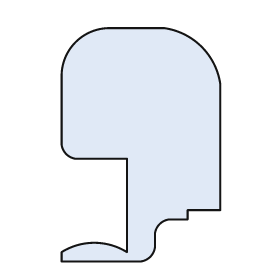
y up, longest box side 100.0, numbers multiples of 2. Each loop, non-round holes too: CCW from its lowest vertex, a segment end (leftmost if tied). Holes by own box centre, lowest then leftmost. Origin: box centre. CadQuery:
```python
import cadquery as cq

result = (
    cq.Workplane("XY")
    .moveTo(-34.0, -50.0)
    .lineTo(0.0, -50.0)
    .threePointArc((4.0, -48.0), (6.0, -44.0))
    .lineTo(6.0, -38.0)
    .threePointArc((8.0, -34.0), (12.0, -32.0))
    .lineTo(20.0, -32.0)
    .lineTo(20.0, -28.0)
    .lineTo(34.0, -28.0)
    .lineTo(34.0, 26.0)
    .threePointArc((26.0, 42.0), (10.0, 50.0))
    .lineTo(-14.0, 50.0)
    .threePointArc((-28.0, 44.0), (-34.0, 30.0))
    .lineTo(-34.0, 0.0)
    .threePointArc((-32.0, -4.0), (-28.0, -6.0))
    .lineTo(-6.0, -6.0)
    .lineTo(-6.0, -46.0)
    .threePointArc((-20.0, -42.0), (-34.0, -46.0))
    .close()
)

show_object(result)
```